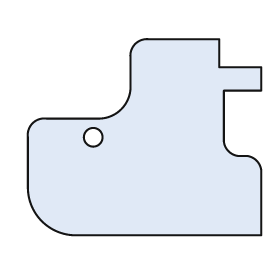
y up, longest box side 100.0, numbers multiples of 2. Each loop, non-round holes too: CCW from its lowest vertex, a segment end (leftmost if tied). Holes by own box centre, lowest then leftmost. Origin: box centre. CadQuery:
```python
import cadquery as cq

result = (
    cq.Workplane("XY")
    .moveTo(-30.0, -42.0)
    .lineTo(50.0, -42.0)
    .lineTo(50.0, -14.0)
    .threePointArc((48.0, -10.0), (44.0, -8.0))
    .lineTo(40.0, -8.0)
    .threePointArc((36.0, -6.0), (34.0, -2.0))
    .lineTo(34.0, 20.0)
    .lineTo(50.0, 20.0)
    .lineTo(50.0, 30.0)
    .lineTo(32.0, 30.0)
    .lineTo(32.0, 42.0)
    .lineTo(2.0, 42.0)
    .threePointArc((-4.0, 40.0), (-6.0, 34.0))
    .lineTo(-6.0, 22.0)
    .threePointArc((-10.0, 12.0), (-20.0, 8.0))
    .lineTo(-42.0, 8.0)
    .threePointArc((-48.0, 6.0), (-50.0, 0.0))
    .lineTo(-50.0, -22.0)
    .threePointArc((-44.0, -36.0), (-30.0, -42.0))
    .close()
    .moveTo(-22.0, 0.0)
    .circle(4.0)
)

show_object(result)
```